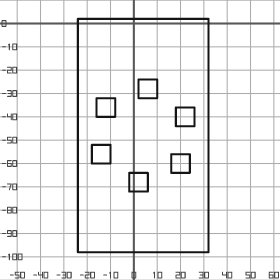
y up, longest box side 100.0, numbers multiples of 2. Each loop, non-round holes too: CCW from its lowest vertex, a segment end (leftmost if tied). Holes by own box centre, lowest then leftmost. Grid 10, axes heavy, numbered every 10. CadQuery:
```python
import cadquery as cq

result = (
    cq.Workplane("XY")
    .moveTo(-24.0, -98.0)
    .lineTo(32.0, -98.0)
    .lineTo(32.0, 2.0)
    .lineTo(-24.0, 2.0)
    .close()
    .moveTo(-2.0, -72.0)
    .lineTo(6.0, -72.0)
    .lineTo(6.0, -64.0)
    .lineTo(-2.0, -64.0)
    .close()
    .moveTo(16.0, -64.0)
    .lineTo(24.0, -64.0)
    .lineTo(24.0, -56.0)
    .lineTo(16.0, -56.0)
    .close()
    .moveTo(-18.0, -60.0)
    .lineTo(-10.0, -60.0)
    .lineTo(-10.0, -52.0)
    .lineTo(-18.0, -52.0)
    .close()
    .moveTo(18.0, -44.0)
    .lineTo(26.0, -44.0)
    .lineTo(26.0, -36.0)
    .lineTo(18.0, -36.0)
    .close()
    .moveTo(-16.0, -40.0)
    .lineTo(-8.0, -40.0)
    .lineTo(-8.0, -32.0)
    .lineTo(-16.0, -32.0)
    .close()
    .moveTo(2.0, -32.0)
    .lineTo(10.0, -32.0)
    .lineTo(10.0, -24.0)
    .lineTo(2.0, -24.0)
    .close()
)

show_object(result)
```